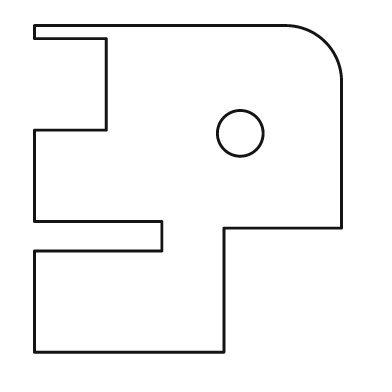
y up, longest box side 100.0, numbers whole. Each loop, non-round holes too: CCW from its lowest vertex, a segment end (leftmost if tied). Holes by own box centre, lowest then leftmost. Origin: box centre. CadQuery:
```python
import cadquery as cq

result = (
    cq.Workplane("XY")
    .moveTo(-47.0, -50.0)
    .lineTo(11.0, -50.0)
    .lineTo(11.0, -12.0)
    .lineTo(47.0, -12.0)
    .lineTo(47.0, 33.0)
    .threePointArc((42.0, 45.0), (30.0, 50.0))
    .lineTo(-47.0, 50.0)
    .lineTo(-47.0, 46.0)
    .lineTo(-25.0, 46.0)
    .lineTo(-25.0, 18.0)
    .lineTo(-47.0, 18.0)
    .lineTo(-47.0, -10.0)
    .lineTo(-8.0, -10.0)
    .lineTo(-8.0, -19.0)
    .lineTo(-47.0, -19.0)
    .close()
    .moveTo(16.0, 17.0)
    .circle(7.0)
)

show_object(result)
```